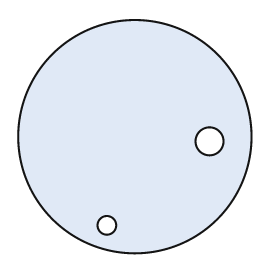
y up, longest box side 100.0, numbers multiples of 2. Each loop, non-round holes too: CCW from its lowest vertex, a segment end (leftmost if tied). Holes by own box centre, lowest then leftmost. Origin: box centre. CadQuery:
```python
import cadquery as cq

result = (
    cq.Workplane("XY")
    .moveTo(0.0, 0.0)
    .circle(50.0)
    .moveTo(-12.0, -38.0)
    .circle(4.0)
    .moveTo(32.0, -2.0)
    .circle(6.0)
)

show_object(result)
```